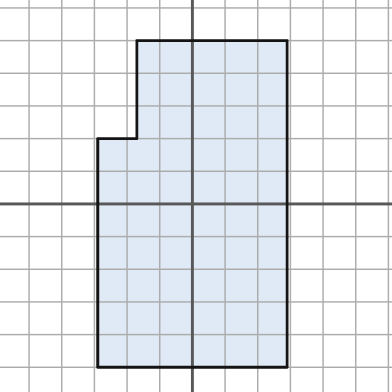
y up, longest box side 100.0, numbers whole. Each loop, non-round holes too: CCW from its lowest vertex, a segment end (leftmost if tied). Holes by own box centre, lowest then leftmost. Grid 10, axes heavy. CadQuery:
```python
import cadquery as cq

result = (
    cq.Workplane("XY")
    .moveTo(-29.0, -50.0)
    .lineTo(29.0, -50.0)
    .lineTo(29.0, 50.0)
    .lineTo(-17.0, 50.0)
    .lineTo(-17.0, 20.0)
    .lineTo(-29.0, 20.0)
    .close()
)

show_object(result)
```